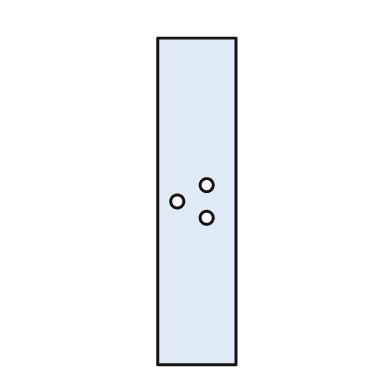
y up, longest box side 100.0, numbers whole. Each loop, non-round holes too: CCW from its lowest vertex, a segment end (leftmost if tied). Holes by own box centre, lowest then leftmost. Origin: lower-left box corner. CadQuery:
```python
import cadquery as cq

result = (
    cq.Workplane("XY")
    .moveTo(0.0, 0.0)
    .lineTo(24.0, 0.0)
    .lineTo(24.0, 100.0)
    .lineTo(0.0, 100.0)
    .close()
    .moveTo(15.0, 45.0)
    .circle(2.0)
    .moveTo(6.0, 50.0)
    .circle(2.0)
    .moveTo(15.0, 55.0)
    .circle(2.0)
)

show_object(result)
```